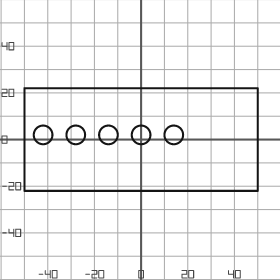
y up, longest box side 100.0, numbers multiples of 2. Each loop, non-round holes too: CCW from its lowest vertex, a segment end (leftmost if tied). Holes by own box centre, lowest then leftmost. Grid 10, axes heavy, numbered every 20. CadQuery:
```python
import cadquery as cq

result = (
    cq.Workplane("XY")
    .moveTo(-50.0, -22.0)
    .lineTo(50.0, -22.0)
    .lineTo(50.0, 22.0)
    .lineTo(-50.0, 22.0)
    .close()
    .moveTo(-42.0, 2.0)
    .circle(4.0)
    .moveTo(-28.0, 2.0)
    .circle(4.0)
    .moveTo(-14.0, 2.0)
    .circle(4.0)
    .moveTo(0.0, 2.0)
    .circle(4.0)
    .moveTo(14.0, 2.0)
    .circle(4.0)
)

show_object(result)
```